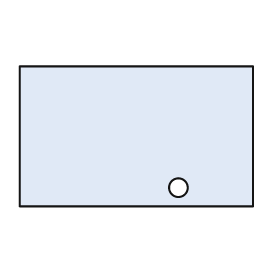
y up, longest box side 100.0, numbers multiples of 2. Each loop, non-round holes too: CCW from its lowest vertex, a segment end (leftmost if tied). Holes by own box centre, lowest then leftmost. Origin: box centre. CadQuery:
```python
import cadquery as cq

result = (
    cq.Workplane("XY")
    .moveTo(-50.0, -30.0)
    .lineTo(50.0, -30.0)
    .lineTo(50.0, 30.0)
    .lineTo(-50.0, 30.0)
    .close()
    .moveTo(18.0, -22.0)
    .circle(4.0)
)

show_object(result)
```